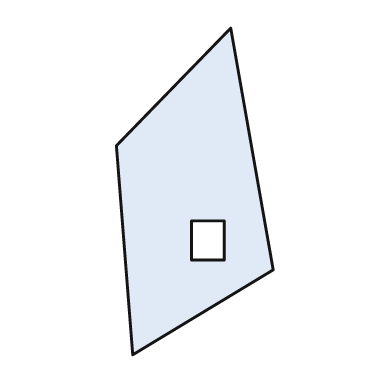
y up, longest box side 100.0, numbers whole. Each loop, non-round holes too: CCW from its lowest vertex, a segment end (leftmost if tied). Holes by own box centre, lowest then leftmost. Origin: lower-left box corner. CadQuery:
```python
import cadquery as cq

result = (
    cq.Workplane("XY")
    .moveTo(5.0, 0.0)
    .lineTo(48.0, 26.0)
    .lineTo(35.0, 100.0)
    .lineTo(0.0, 64.0)
    .close()
    .moveTo(23.0, 29.0)
    .lineTo(33.0, 29.0)
    .lineTo(33.0, 41.0)
    .lineTo(23.0, 41.0)
    .close()
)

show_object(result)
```